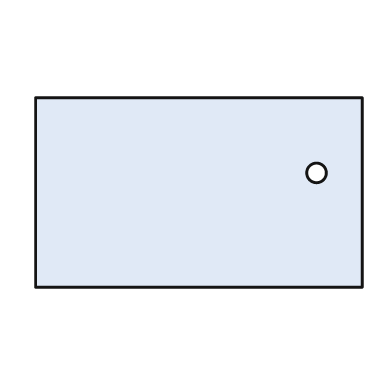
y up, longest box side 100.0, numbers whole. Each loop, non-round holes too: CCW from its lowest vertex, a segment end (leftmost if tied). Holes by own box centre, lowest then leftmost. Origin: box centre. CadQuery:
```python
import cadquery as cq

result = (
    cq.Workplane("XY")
    .moveTo(-50.0, -29.0)
    .lineTo(50.0, -29.0)
    .lineTo(50.0, 29.0)
    .lineTo(-50.0, 29.0)
    .close()
    .moveTo(36.0, 6.0)
    .circle(3.0)
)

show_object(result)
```